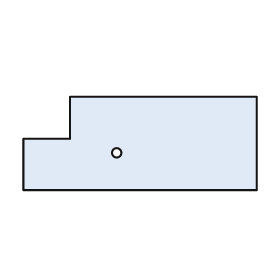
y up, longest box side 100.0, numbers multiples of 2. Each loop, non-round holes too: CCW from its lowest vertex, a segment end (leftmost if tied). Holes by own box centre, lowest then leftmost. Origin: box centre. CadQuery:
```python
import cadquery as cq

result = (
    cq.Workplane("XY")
    .moveTo(-50.0, -20.0)
    .lineTo(50.0, -20.0)
    .lineTo(50.0, 20.0)
    .lineTo(-30.0, 20.0)
    .lineTo(-30.0, 2.0)
    .lineTo(-50.0, 2.0)
    .close()
    .moveTo(-10.0, -4.0)
    .circle(2.0)
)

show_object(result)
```